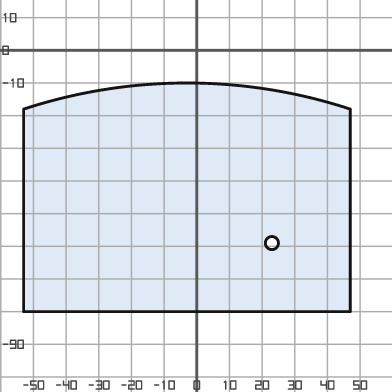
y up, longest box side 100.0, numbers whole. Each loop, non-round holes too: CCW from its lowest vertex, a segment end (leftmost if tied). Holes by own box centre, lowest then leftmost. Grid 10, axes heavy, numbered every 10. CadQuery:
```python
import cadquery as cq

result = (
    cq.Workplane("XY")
    .moveTo(-53.0, -80.0)
    .lineTo(47.0, -80.0)
    .lineTo(47.0, -18.0)
    .threePointArc((-3.0, -10.0), (-53.0, -18.0))
    .close()
    .moveTo(23.0, -59.0)
    .circle(2.0)
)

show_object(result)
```